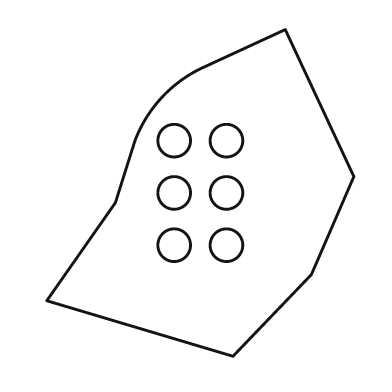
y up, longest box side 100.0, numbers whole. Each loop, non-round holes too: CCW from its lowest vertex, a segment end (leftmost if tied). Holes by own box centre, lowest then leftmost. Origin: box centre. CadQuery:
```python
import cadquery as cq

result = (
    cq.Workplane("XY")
    .moveTo(10.0, -50.0)
    .lineTo(34.0, -25.0)
    .lineTo(47.0, 5.0)
    .lineTo(26.0, 50.0)
    .lineTo(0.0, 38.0)
    .threePointArc((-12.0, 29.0), (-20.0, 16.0))
    .lineTo(-26.0, -3.0)
    .lineTo(-47.0, -33.0)
    .close()
    .moveTo(-8.0, -16.0)
    .circle(5.0)
    .moveTo(8.0, -16.0)
    .circle(5.0)
    .moveTo(-8.0, 0.0)
    .circle(5.0)
    .moveTo(8.0, 0.0)
    .circle(5.0)
    .moveTo(-8.0, 16.0)
    .circle(5.0)
    .moveTo(8.0, 16.0)
    .circle(5.0)
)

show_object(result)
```